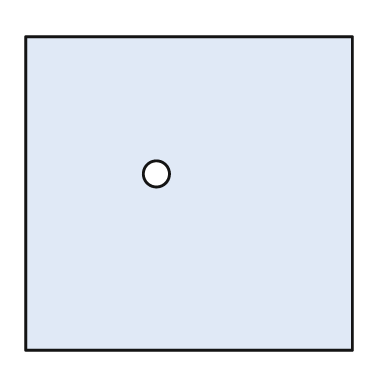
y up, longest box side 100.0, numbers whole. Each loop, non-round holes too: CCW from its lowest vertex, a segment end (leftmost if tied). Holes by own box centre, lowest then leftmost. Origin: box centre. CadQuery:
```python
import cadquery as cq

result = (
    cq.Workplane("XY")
    .moveTo(-50.0, -48.0)
    .lineTo(50.0, -48.0)
    .lineTo(50.0, 48.0)
    .lineTo(-50.0, 48.0)
    .close()
    .moveTo(-10.0, 6.0)
    .circle(4.0)
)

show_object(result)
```